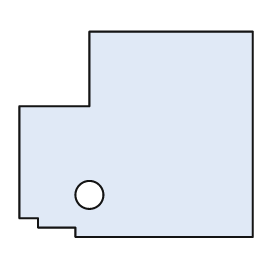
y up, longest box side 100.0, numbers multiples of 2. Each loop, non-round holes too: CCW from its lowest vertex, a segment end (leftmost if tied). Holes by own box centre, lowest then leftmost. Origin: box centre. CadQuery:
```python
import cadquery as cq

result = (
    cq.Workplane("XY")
    .moveTo(-26.0, -44.0)
    .lineTo(50.0, -44.0)
    .lineTo(50.0, 44.0)
    .lineTo(-20.0, 44.0)
    .lineTo(-20.0, 12.0)
    .lineTo(-50.0, 12.0)
    .lineTo(-50.0, -36.0)
    .lineTo(-42.0, -36.0)
    .lineTo(-42.0, -40.0)
    .lineTo(-26.0, -40.0)
    .close()
    .moveTo(-20.0, -26.0)
    .circle(6.0)
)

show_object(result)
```